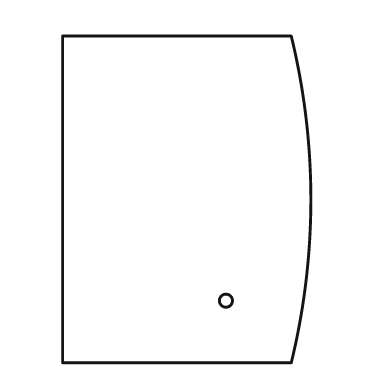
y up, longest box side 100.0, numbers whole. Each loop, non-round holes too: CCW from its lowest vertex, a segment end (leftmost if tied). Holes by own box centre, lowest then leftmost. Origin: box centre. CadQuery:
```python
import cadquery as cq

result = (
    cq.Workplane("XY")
    .moveTo(-38.0, -50.0)
    .lineTo(32.0, -50.0)
    .threePointArc((38.0, 0.0), (32.0, 50.0))
    .lineTo(-38.0, 50.0)
    .close()
    .moveTo(12.0, -31.0)
    .circle(2.0)
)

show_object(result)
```